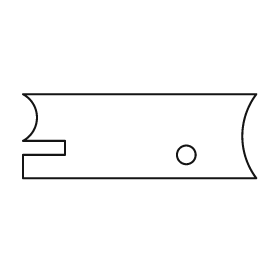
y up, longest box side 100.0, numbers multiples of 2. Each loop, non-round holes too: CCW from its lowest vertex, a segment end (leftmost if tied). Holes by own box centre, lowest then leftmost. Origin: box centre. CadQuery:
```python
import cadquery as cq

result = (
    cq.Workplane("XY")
    .moveTo(-50.0, -18.0)
    .lineTo(50.0, -18.0)
    .threePointArc((44.0, 0.0), (50.0, 18.0))
    .lineTo(-50.0, 18.0)
    .threePointArc((-44.0, 8.0), (-50.0, -2.0))
    .lineTo(-32.0, -2.0)
    .lineTo(-32.0, -8.0)
    .lineTo(-50.0, -8.0)
    .close()
    .moveTo(20.0, -8.0)
    .circle(4.0)
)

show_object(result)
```